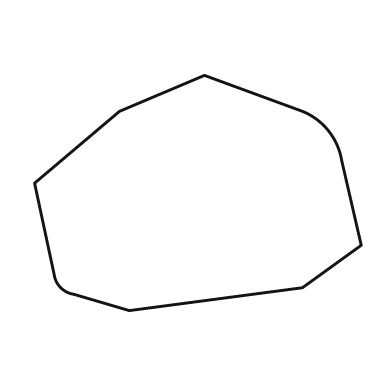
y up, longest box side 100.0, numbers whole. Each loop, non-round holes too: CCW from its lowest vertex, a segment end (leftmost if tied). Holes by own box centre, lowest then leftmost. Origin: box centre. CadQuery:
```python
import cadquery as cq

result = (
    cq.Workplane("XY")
    .moveTo(-21.0, -36.0)
    .lineTo(32.0, -29.0)
    .lineTo(50.0, -16.0)
    .lineTo(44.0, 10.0)
    .threePointArc((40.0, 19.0), (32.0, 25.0))
    .lineTo(2.0, 36.0)
    .lineTo(-24.0, 25.0)
    .lineTo(-50.0, 3.0)
    .lineTo(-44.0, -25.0)
    .threePointArc((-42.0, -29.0), (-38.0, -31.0))
    .close()
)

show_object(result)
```